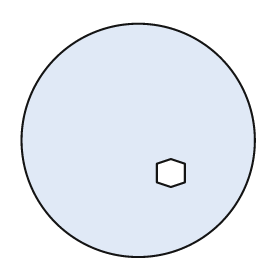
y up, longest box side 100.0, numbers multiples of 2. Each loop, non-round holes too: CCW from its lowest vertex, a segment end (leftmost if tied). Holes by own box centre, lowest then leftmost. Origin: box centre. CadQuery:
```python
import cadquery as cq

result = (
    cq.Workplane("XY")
    .moveTo(0.0, 0.0)
    .circle(50.0)
    .moveTo(14.0, -20.0)
    .lineTo(20.0, -18.0)
    .lineTo(20.0, -10.0)
    .lineTo(14.0, -8.0)
    .lineTo(8.0, -10.0)
    .lineTo(8.0, -18.0)
    .close()
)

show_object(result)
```